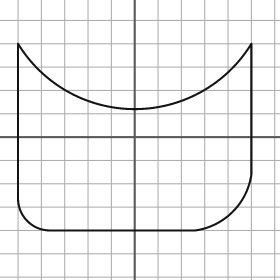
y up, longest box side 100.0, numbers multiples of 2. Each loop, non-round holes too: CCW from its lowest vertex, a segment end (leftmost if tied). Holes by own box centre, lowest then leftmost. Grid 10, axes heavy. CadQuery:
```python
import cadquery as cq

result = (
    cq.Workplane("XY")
    .moveTo(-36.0, -40.0)
    .lineTo(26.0, -40.0)
    .threePointArc((42.0, -32.0), (50.0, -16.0))
    .lineTo(50.0, 40.0)
    .threePointArc((0.0, 12.0), (-50.0, 40.0))
    .lineTo(-50.0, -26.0)
    .threePointArc((-46.0, -36.0), (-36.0, -40.0))
    .close()
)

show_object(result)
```